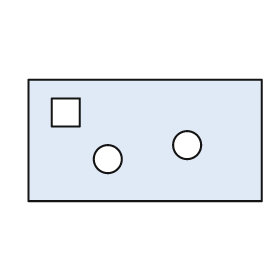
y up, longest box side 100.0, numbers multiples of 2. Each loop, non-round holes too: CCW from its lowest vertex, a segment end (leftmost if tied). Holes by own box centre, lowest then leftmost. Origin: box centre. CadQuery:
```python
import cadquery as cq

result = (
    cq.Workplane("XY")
    .moveTo(-50.0, -26.0)
    .lineTo(50.0, -26.0)
    .lineTo(50.0, 26.0)
    .lineTo(-50.0, 26.0)
    .close()
    .moveTo(-16.0, -8.0)
    .circle(6.0)
    .moveTo(18.0, -2.0)
    .circle(6.0)
    .moveTo(-40.0, 6.0)
    .lineTo(-28.0, 6.0)
    .lineTo(-28.0, 18.0)
    .lineTo(-40.0, 18.0)
    .close()
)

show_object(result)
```